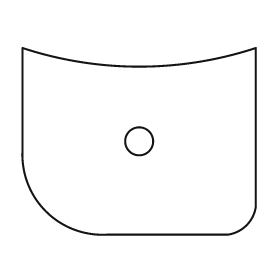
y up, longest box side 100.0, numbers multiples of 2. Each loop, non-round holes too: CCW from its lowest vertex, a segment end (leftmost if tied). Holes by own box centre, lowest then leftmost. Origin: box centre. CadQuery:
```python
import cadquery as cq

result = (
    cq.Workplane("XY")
    .moveTo(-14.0, -40.0)
    .lineTo(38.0, -40.0)
    .threePointArc((46.0, -36.0), (50.0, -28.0))
    .lineTo(50.0, 40.0)
    .threePointArc((0.0, 32.0), (-50.0, 40.0))
    .lineTo(-50.0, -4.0)
    .threePointArc((-40.0, -30.0), (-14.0, -40.0))
    .close()
    .moveTo(0.0, 0.0)
    .circle(6.0)
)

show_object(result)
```